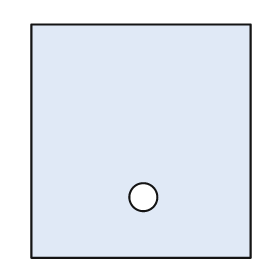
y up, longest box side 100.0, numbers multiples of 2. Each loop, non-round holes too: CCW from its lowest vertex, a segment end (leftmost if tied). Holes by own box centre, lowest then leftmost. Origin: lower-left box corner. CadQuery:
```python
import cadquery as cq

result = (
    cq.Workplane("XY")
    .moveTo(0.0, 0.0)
    .lineTo(94.0, 0.0)
    .lineTo(94.0, 100.0)
    .lineTo(0.0, 100.0)
    .close()
    .moveTo(48.0, 26.0)
    .circle(6.0)
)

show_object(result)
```